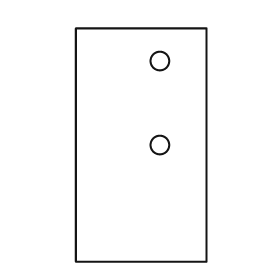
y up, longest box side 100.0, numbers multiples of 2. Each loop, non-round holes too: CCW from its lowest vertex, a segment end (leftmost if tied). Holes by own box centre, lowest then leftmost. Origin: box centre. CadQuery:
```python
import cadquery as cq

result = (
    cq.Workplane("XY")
    .moveTo(-28.0, -50.0)
    .lineTo(28.0, -50.0)
    .lineTo(28.0, 50.0)
    .lineTo(-28.0, 50.0)
    .close()
    .moveTo(8.0, 0.0)
    .circle(4.0)
    .moveTo(8.0, 36.0)
    .circle(4.0)
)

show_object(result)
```